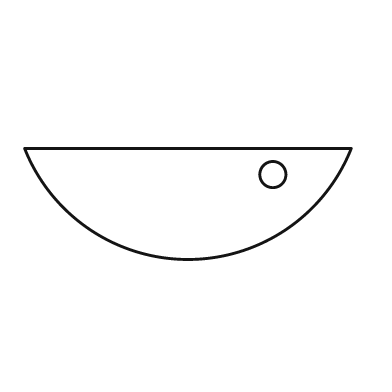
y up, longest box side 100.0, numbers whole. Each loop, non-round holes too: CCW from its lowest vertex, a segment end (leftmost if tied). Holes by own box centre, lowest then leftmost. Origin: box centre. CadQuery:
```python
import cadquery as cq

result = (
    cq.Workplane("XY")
    .moveTo(-50.0, 17.0)
    .threePointArc((0.0, -17.0), (50.0, 17.0))
    .close()
    .moveTo(26.0, 9.0)
    .circle(4.0)
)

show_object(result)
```